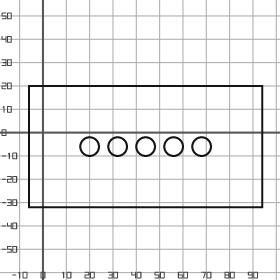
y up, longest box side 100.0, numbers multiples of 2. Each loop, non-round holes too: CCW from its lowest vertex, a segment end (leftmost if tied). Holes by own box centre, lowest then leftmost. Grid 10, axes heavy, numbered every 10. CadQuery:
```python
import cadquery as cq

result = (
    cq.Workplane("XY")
    .moveTo(-6.0, -32.0)
    .lineTo(94.0, -32.0)
    .lineTo(94.0, 20.0)
    .lineTo(-6.0, 20.0)
    .close()
    .moveTo(20.0, -6.0)
    .circle(4.0)
    .moveTo(32.0, -6.0)
    .circle(4.0)
    .moveTo(44.0, -6.0)
    .circle(4.0)
    .moveTo(56.0, -6.0)
    .circle(4.0)
    .moveTo(68.0, -6.0)
    .circle(4.0)
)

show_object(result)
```